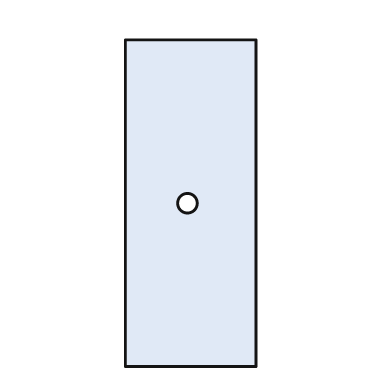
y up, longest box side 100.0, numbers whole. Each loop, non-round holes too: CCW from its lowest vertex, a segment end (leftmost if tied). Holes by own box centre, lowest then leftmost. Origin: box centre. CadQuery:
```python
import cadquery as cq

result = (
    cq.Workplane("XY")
    .moveTo(-20.0, -50.0)
    .lineTo(20.0, -50.0)
    .lineTo(20.0, 50.0)
    .lineTo(-20.0, 50.0)
    .close()
    .moveTo(-1.0, 0.0)
    .circle(3.0)
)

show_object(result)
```